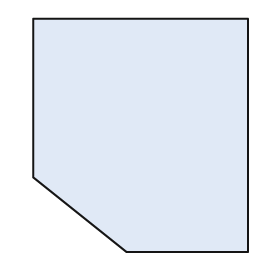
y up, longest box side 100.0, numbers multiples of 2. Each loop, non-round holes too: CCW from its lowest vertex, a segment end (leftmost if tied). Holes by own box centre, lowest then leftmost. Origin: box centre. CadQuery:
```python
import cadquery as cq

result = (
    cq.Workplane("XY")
    .moveTo(-6.0, -50.0)
    .lineTo(46.0, -50.0)
    .lineTo(46.0, 50.0)
    .lineTo(-46.0, 50.0)
    .lineTo(-46.0, -18.0)
    .close()
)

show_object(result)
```